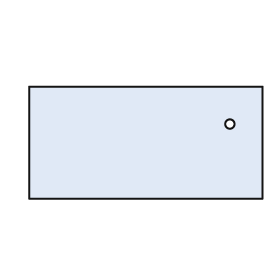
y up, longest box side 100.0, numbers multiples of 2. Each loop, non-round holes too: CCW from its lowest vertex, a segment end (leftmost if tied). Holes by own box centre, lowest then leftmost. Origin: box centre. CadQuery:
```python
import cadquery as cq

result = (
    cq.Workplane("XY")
    .moveTo(-50.0, -24.0)
    .lineTo(50.0, -24.0)
    .lineTo(50.0, 24.0)
    .lineTo(-50.0, 24.0)
    .close()
    .moveTo(36.0, 8.0)
    .circle(2.0)
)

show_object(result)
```